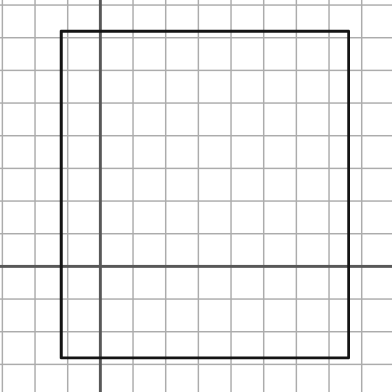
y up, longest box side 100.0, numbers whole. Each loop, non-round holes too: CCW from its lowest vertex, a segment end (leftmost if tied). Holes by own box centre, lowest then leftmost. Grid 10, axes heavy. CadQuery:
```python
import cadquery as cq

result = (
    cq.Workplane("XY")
    .moveTo(-12.0, -28.0)
    .lineTo(76.0, -28.0)
    .lineTo(76.0, 72.0)
    .lineTo(-12.0, 72.0)
    .close()
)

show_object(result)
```